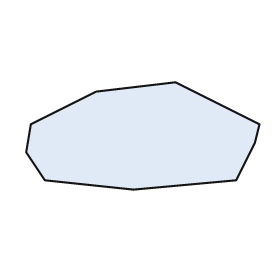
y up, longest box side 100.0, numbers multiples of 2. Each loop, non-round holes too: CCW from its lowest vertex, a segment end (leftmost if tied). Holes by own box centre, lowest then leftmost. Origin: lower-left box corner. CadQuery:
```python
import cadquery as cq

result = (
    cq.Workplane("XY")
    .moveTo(46.0, 0.0)
    .lineTo(90.0, 4.0)
    .lineTo(98.0, 20.0)
    .lineTo(100.0, 28.0)
    .lineTo(64.0, 46.0)
    .lineTo(30.0, 42.0)
    .lineTo(2.0, 28.0)
    .lineTo(0.0, 16.0)
    .lineTo(8.0, 4.0)
    .close()
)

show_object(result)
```